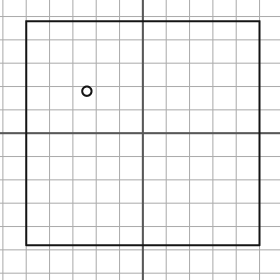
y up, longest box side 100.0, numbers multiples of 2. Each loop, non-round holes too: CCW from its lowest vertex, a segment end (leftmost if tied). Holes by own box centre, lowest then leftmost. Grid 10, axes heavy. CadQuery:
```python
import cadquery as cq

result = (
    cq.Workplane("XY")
    .moveTo(-50.0, -48.0)
    .lineTo(50.0, -48.0)
    .lineTo(50.0, 48.0)
    .lineTo(-50.0, 48.0)
    .close()
    .moveTo(-24.0, 18.0)
    .circle(2.0)
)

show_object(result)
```